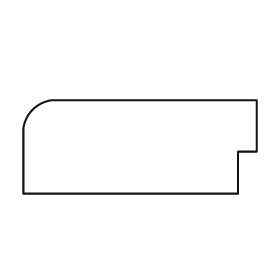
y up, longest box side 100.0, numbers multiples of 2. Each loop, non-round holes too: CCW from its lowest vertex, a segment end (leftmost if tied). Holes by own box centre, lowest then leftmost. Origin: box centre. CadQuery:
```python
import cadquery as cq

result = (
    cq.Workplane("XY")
    .moveTo(-50.0, -20.0)
    .lineTo(42.0, -20.0)
    .lineTo(42.0, -2.0)
    .lineTo(50.0, -2.0)
    .lineTo(50.0, 20.0)
    .lineTo(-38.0, 20.0)
    .threePointArc((-46.0, 16.0), (-50.0, 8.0))
    .close()
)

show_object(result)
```